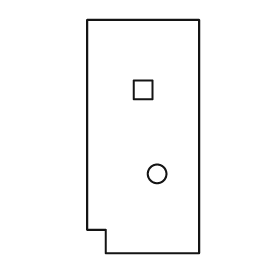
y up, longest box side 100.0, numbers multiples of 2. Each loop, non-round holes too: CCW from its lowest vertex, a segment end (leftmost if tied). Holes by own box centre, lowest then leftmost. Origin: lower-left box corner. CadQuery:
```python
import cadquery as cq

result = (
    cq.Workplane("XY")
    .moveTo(8.0, 0.0)
    .lineTo(48.0, 0.0)
    .lineTo(48.0, 100.0)
    .lineTo(0.0, 100.0)
    .lineTo(0.0, 10.0)
    .lineTo(8.0, 10.0)
    .close()
    .moveTo(30.0, 34.0)
    .circle(4.0)
    .moveTo(20.0, 66.0)
    .lineTo(28.0, 66.0)
    .lineTo(28.0, 74.0)
    .lineTo(20.0, 74.0)
    .close()
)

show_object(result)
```